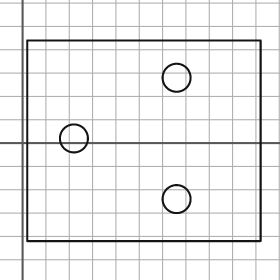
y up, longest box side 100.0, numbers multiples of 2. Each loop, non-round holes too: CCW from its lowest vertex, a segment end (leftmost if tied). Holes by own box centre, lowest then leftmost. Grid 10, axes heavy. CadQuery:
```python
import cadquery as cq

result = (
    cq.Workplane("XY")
    .moveTo(2.0, -42.0)
    .lineTo(102.0, -42.0)
    .lineTo(102.0, 44.0)
    .lineTo(2.0, 44.0)
    .close()
    .moveTo(66.0, -24.0)
    .circle(6.0)
    .moveTo(22.0, 2.0)
    .circle(6.0)
    .moveTo(66.0, 28.0)
    .circle(6.0)
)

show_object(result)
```